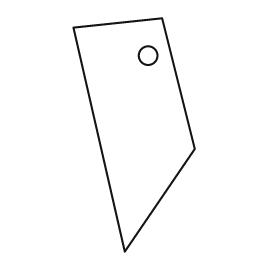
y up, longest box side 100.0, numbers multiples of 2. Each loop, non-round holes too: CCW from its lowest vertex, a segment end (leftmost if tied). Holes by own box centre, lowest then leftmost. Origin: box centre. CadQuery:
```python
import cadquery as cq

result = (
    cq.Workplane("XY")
    .moveTo(-4.0, -50.0)
    .lineTo(26.0, -6.0)
    .lineTo(12.0, 50.0)
    .lineTo(-26.0, 46.0)
    .close()
    .moveTo(6.0, 34.0)
    .circle(4.0)
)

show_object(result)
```